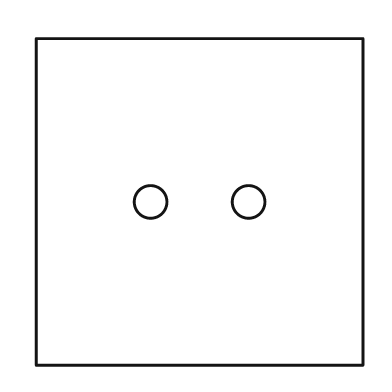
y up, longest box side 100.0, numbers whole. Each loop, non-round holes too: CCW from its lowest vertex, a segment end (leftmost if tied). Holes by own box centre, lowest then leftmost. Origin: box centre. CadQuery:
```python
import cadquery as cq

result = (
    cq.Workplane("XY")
    .moveTo(-50.0, -50.0)
    .lineTo(50.0, -50.0)
    .lineTo(50.0, 50.0)
    .lineTo(-50.0, 50.0)
    .close()
    .moveTo(-15.0, 0.0)
    .circle(5.0)
    .moveTo(15.0, 0.0)
    .circle(5.0)
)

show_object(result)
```